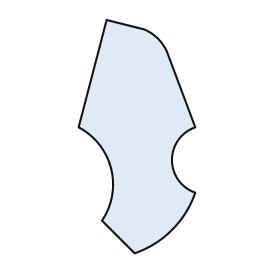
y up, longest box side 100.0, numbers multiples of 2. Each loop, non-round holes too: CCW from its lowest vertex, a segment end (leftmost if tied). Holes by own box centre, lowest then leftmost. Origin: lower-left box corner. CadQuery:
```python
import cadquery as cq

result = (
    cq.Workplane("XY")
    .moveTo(24.0, 0.0)
    .threePointArc((40.0, 10.0), (50.0, 26.0))
    .threePointArc((40.0, 40.0), (50.0, 54.0))
    .lineTo(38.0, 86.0)
    .threePointArc((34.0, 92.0), (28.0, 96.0))
    .lineTo(12.0, 100.0)
    .lineTo(0.0, 54.0)
    .threePointArc((14.0, 36.0), (10.0, 14.0))
    .close()
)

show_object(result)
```